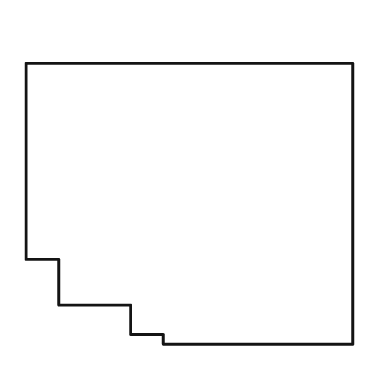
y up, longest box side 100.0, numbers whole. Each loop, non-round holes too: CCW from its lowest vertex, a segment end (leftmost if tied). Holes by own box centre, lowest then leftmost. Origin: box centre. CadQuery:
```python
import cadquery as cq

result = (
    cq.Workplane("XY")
    .moveTo(-8.0, -43.0)
    .lineTo(50.0, -43.0)
    .lineTo(50.0, 43.0)
    .lineTo(-50.0, 43.0)
    .lineTo(-50.0, -17.0)
    .lineTo(-40.0, -17.0)
    .lineTo(-40.0, -31.0)
    .lineTo(-18.0, -31.0)
    .lineTo(-18.0, -40.0)
    .lineTo(-8.0, -40.0)
    .close()
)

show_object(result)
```